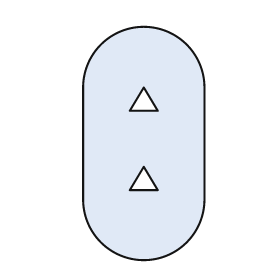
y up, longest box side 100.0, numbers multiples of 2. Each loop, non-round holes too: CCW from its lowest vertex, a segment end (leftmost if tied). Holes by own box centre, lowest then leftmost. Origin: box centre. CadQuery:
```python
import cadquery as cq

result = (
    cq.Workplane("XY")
    .moveTo(-26.0, -24.0)
    .threePointArc((0.0, -50.0), (26.0, -24.0))
    .lineTo(26.0, 24.0)
    .threePointArc((0.0, 50.0), (-26.0, 24.0))
    .close()
    .moveTo(-6.0, -20.0)
    .lineTo(6.0, -20.0)
    .lineTo(0.0, -10.0)
    .close()
    .moveTo(-6.0, 14.0)
    .lineTo(6.0, 14.0)
    .lineTo(0.0, 24.0)
    .close()
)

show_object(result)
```